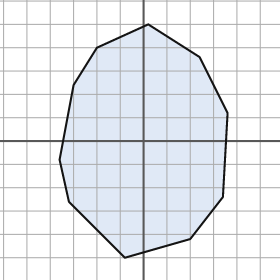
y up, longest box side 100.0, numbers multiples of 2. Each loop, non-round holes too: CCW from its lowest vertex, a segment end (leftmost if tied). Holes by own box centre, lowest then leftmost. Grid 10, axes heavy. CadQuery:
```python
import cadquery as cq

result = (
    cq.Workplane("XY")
    .moveTo(-8.0, -50.0)
    .lineTo(20.0, -42.0)
    .lineTo(34.0, -24.0)
    .lineTo(36.0, 12.0)
    .lineTo(24.0, 36.0)
    .lineTo(2.0, 50.0)
    .lineTo(-20.0, 40.0)
    .lineTo(-30.0, 24.0)
    .lineTo(-36.0, -8.0)
    .lineTo(-32.0, -26.0)
    .close()
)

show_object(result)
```